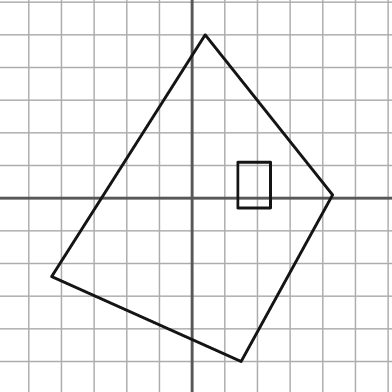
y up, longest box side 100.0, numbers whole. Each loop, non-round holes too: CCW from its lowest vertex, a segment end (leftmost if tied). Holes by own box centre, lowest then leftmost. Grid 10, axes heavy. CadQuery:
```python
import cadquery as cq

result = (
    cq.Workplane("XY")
    .moveTo(15.0, -50.0)
    .lineTo(43.0, 1.0)
    .lineTo(4.0, 50.0)
    .lineTo(-43.0, -24.0)
    .close()
    .moveTo(14.0, -3.0)
    .lineTo(24.0, -3.0)
    .lineTo(24.0, 11.0)
    .lineTo(14.0, 11.0)
    .close()
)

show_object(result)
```